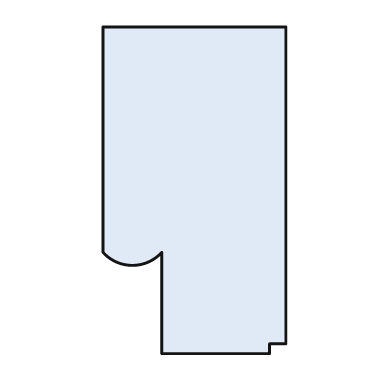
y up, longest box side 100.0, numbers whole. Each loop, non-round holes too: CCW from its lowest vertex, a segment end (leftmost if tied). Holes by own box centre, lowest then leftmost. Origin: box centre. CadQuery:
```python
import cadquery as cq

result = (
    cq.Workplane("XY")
    .moveTo(-10.0, -50.0)
    .lineTo(23.0, -50.0)
    .lineTo(23.0, -47.0)
    .lineTo(28.0, -47.0)
    .lineTo(28.0, 50.0)
    .lineTo(-28.0, 50.0)
    .lineTo(-28.0, -19.0)
    .threePointArc((-19.0, -23.0), (-10.0, -19.0))
    .close()
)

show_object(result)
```